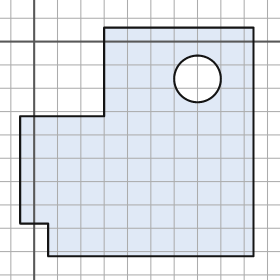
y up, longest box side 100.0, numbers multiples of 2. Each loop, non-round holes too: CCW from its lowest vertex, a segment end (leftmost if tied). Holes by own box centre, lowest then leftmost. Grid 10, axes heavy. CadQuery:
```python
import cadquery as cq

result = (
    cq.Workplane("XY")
    .moveTo(6.0, -92.0)
    .lineTo(94.0, -92.0)
    .lineTo(94.0, 6.0)
    .lineTo(30.0, 6.0)
    .lineTo(30.0, -32.0)
    .lineTo(-6.0, -32.0)
    .lineTo(-6.0, -78.0)
    .lineTo(6.0, -78.0)
    .close()
    .moveTo(70.0, -16.0)
    .circle(10.0)
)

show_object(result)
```